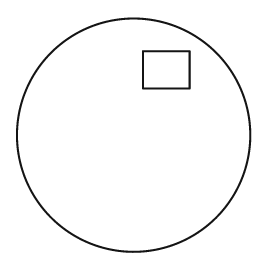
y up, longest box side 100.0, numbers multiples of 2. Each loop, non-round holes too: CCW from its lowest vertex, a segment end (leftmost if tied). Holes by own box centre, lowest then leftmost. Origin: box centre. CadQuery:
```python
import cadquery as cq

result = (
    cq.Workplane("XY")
    .moveTo(0.0, 0.0)
    .circle(50.0)
    .moveTo(4.0, 20.0)
    .lineTo(24.0, 20.0)
    .lineTo(24.0, 36.0)
    .lineTo(4.0, 36.0)
    .close()
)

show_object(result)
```